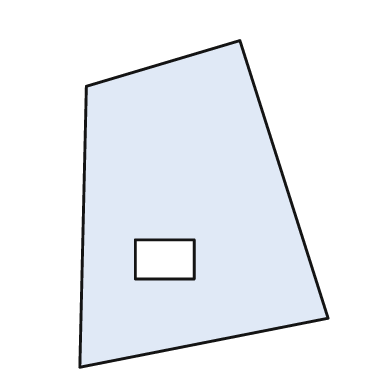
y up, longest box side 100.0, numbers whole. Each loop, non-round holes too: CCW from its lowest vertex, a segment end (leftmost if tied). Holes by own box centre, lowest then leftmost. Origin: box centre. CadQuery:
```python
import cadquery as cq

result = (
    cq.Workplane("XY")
    .moveTo(-38.0, -50.0)
    .lineTo(38.0, -35.0)
    .lineTo(11.0, 50.0)
    .lineTo(-36.0, 36.0)
    .close()
    .moveTo(-21.0, -23.0)
    .lineTo(-3.0, -23.0)
    .lineTo(-3.0, -11.0)
    .lineTo(-21.0, -11.0)
    .close()
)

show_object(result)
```